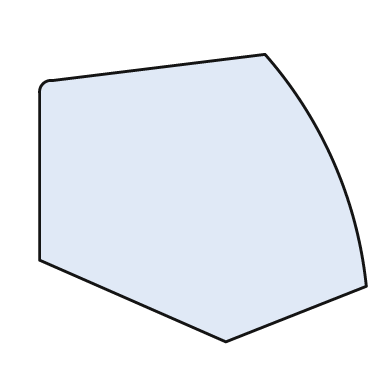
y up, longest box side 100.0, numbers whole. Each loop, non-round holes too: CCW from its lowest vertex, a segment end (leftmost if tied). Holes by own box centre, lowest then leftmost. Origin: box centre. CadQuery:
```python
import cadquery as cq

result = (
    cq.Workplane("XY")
    .moveTo(7.0, -44.0)
    .lineTo(50.0, -27.0)
    .threePointArc((40.0, 11.0), (19.0, 44.0))
    .lineTo(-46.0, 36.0)
    .threePointArc((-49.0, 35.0), (-50.0, 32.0))
    .lineTo(-50.0, -19.0)
    .close()
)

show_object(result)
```